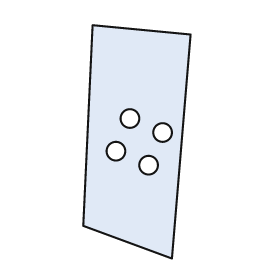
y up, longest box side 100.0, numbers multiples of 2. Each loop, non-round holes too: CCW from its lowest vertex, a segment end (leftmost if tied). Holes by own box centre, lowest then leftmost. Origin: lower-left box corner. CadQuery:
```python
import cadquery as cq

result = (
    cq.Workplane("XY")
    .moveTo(38.0, 0.0)
    .lineTo(46.0, 96.0)
    .lineTo(4.0, 100.0)
    .lineTo(0.0, 14.0)
    .close()
    .moveTo(28.0, 40.0)
    .circle(4.0)
    .moveTo(14.0, 46.0)
    .circle(4.0)
    .moveTo(34.0, 54.0)
    .circle(4.0)
    .moveTo(20.0, 60.0)
    .circle(4.0)
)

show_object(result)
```